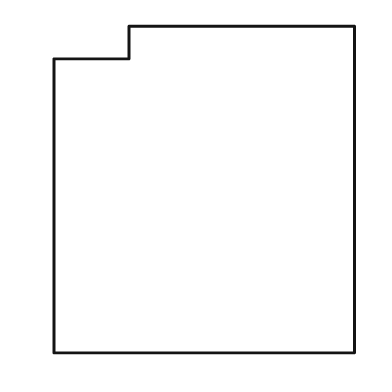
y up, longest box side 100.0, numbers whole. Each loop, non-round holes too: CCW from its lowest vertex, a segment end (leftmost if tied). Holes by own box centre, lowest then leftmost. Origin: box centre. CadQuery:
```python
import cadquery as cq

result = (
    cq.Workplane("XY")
    .moveTo(-46.0, -50.0)
    .lineTo(46.0, -50.0)
    .lineTo(46.0, 50.0)
    .lineTo(-23.0, 50.0)
    .lineTo(-23.0, 40.0)
    .lineTo(-46.0, 40.0)
    .close()
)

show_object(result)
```